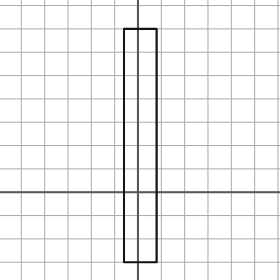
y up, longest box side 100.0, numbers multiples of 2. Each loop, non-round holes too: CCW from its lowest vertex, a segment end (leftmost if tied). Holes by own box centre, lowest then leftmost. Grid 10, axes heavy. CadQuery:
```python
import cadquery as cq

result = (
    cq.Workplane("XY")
    .moveTo(-6.0, -30.0)
    .lineTo(8.0, -30.0)
    .lineTo(8.0, 70.0)
    .lineTo(-6.0, 70.0)
    .close()
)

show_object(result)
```